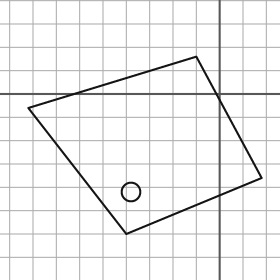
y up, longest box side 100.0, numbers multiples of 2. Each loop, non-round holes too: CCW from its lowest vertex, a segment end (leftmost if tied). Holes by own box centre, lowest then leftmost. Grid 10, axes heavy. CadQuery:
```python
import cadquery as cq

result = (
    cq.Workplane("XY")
    .moveTo(-40.0, -60.0)
    .lineTo(18.0, -36.0)
    .lineTo(-10.0, 16.0)
    .lineTo(-82.0, -6.0)
    .close()
    .moveTo(-38.0, -42.0)
    .circle(4.0)
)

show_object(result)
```